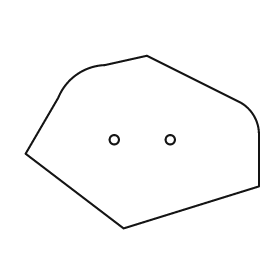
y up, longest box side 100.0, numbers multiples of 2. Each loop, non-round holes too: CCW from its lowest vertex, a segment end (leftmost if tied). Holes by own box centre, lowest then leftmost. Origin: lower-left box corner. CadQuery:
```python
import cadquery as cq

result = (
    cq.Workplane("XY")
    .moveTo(42.0, 0.0)
    .lineTo(100.0, 18.0)
    .lineTo(100.0, 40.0)
    .threePointArc((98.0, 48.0), (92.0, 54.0))
    .lineTo(52.0, 74.0)
    .lineTo(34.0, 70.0)
    .threePointArc((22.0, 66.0), (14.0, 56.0))
    .lineTo(0.0, 32.0)
    .close()
    .moveTo(38.0, 38.0)
    .circle(2.0)
    .moveTo(62.0, 38.0)
    .circle(2.0)
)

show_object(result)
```